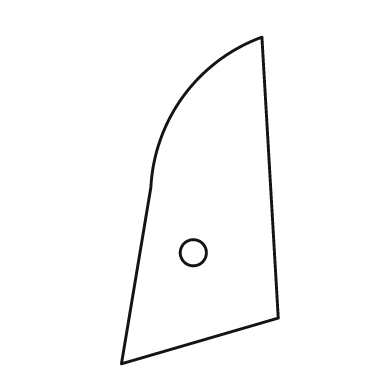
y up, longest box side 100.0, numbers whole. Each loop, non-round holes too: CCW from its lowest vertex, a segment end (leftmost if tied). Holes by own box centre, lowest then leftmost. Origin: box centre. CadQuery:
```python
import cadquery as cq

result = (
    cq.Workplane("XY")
    .moveTo(-24.0, -50.0)
    .lineTo(24.0, -36.0)
    .lineTo(19.0, 50.0)
    .threePointArc((-5.0, 32.0), (-15.0, 4.0))
    .close()
    .moveTo(-2.0, -16.0)
    .circle(4.0)
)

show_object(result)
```